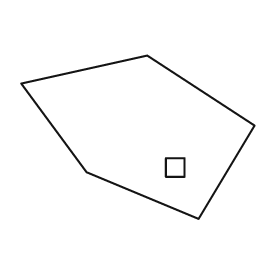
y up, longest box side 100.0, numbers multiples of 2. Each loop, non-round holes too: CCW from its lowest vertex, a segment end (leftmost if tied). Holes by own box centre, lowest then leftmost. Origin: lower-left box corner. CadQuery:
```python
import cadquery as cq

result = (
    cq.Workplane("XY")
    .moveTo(76.0, 0.0)
    .lineTo(100.0, 40.0)
    .lineTo(54.0, 70.0)
    .lineTo(0.0, 58.0)
    .lineTo(28.0, 20.0)
    .close()
    .moveTo(62.0, 18.0)
    .lineTo(70.0, 18.0)
    .lineTo(70.0, 26.0)
    .lineTo(62.0, 26.0)
    .close()
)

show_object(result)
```